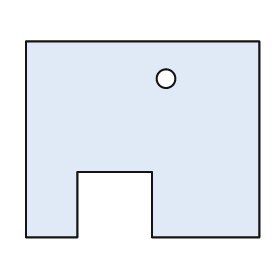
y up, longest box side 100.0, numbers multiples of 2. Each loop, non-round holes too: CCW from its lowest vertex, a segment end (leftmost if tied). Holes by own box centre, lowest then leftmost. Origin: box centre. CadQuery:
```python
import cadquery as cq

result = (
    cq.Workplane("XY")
    .moveTo(-50.0, -42.0)
    .lineTo(-28.0, -42.0)
    .lineTo(-28.0, -14.0)
    .lineTo(4.0, -14.0)
    .lineTo(4.0, -42.0)
    .lineTo(50.0, -42.0)
    .lineTo(50.0, 42.0)
    .lineTo(-50.0, 42.0)
    .close()
    .moveTo(10.0, 26.0)
    .circle(4.0)
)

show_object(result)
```